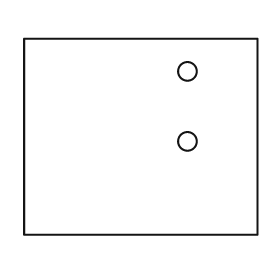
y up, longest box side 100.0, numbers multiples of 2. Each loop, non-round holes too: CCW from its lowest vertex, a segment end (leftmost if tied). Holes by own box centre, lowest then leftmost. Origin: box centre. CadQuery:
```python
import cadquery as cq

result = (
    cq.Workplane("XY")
    .moveTo(-50.0, -42.0)
    .lineTo(50.0, -42.0)
    .lineTo(50.0, 42.0)
    .lineTo(-50.0, 42.0)
    .close()
    .moveTo(20.0, -2.0)
    .circle(4.0)
    .moveTo(20.0, 28.0)
    .circle(4.0)
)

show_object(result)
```